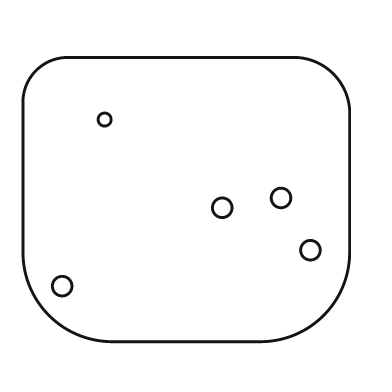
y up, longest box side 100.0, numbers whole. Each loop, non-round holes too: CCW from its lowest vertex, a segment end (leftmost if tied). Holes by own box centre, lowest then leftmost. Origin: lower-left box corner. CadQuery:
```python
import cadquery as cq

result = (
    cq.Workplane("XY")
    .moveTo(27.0, 0.0)
    .lineTo(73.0, 0.0)
    .threePointArc((92.0, 8.0), (100.0, 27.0))
    .lineTo(100.0, 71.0)
    .threePointArc((95.0, 82.0), (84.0, 87.0))
    .lineTo(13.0, 87.0)
    .threePointArc((4.0, 83.0), (0.0, 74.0))
    .lineTo(0.0, 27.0)
    .threePointArc((8.0, 8.0), (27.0, 0.0))
    .close()
    .moveTo(12.0, 17.0)
    .circle(3.0)
    .moveTo(88.0, 28.0)
    .circle(3.0)
    .moveTo(61.0, 41.0)
    .circle(3.0)
    .moveTo(79.0, 44.0)
    .circle(3.0)
    .moveTo(25.0, 68.0)
    .circle(2.0)
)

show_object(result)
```